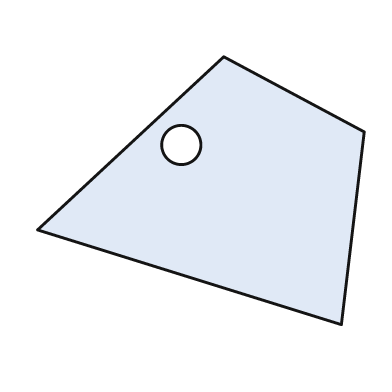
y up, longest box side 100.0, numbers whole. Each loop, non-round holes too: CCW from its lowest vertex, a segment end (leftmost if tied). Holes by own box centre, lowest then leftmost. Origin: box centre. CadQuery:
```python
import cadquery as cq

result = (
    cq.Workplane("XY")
    .moveTo(43.0, -41.0)
    .lineTo(50.0, 18.0)
    .lineTo(7.0, 41.0)
    .lineTo(-50.0, -12.0)
    .close()
    .moveTo(-6.0, 14.0)
    .circle(6.0)
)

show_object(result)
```